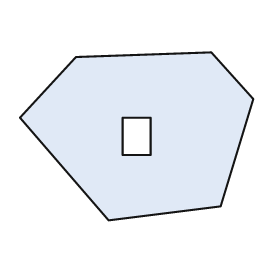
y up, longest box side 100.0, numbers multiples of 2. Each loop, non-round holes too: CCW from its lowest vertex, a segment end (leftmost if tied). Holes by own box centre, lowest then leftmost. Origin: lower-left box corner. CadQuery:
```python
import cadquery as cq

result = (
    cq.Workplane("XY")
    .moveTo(38.0, 0.0)
    .lineTo(86.0, 6.0)
    .lineTo(100.0, 52.0)
    .lineTo(82.0, 72.0)
    .lineTo(24.0, 70.0)
    .lineTo(0.0, 44.0)
    .close()
    .moveTo(44.0, 28.0)
    .lineTo(56.0, 28.0)
    .lineTo(56.0, 44.0)
    .lineTo(44.0, 44.0)
    .close()
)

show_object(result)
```